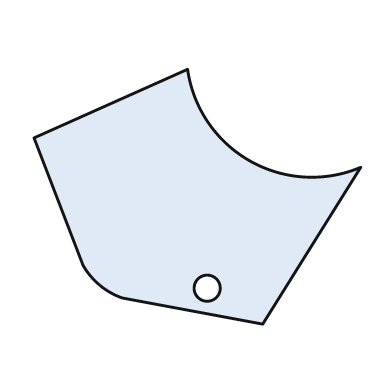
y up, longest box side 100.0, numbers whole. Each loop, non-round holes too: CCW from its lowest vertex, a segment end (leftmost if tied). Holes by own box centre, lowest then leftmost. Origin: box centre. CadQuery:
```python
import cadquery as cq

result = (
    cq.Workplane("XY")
    .moveTo(20.0, -39.0)
    .lineTo(50.0, 9.0)
    .threePointArc((16.0, 11.0), (-3.0, 39.0))
    .lineTo(-50.0, 18.0)
    .lineTo(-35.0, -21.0)
    .threePointArc((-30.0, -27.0), (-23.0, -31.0))
    .close()
    .moveTo(3.0, -28.0)
    .circle(4.0)
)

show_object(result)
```